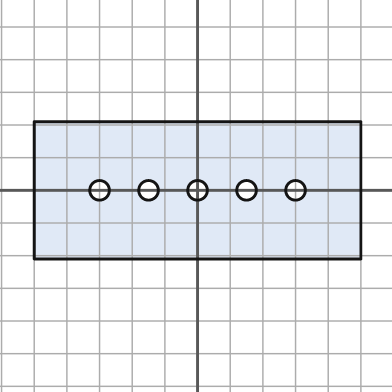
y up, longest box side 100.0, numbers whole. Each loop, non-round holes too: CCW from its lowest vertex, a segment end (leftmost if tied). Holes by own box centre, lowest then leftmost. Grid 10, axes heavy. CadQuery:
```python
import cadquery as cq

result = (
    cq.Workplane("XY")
    .moveTo(-50.0, -21.0)
    .lineTo(50.0, -21.0)
    .lineTo(50.0, 21.0)
    .lineTo(-50.0, 21.0)
    .close()
    .moveTo(-30.0, 0.0)
    .circle(3.0)
    .moveTo(-15.0, 0.0)
    .circle(3.0)
    .moveTo(0.0, 0.0)
    .circle(3.0)
    .moveTo(15.0, 0.0)
    .circle(3.0)
    .moveTo(30.0, 0.0)
    .circle(3.0)
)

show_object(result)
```